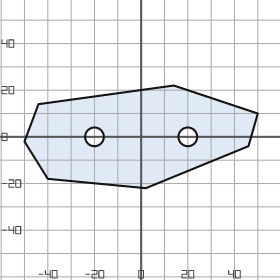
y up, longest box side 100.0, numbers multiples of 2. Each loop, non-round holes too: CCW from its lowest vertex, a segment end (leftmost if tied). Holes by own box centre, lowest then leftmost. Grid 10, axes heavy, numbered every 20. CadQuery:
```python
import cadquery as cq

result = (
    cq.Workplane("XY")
    .moveTo(2.0, -22.0)
    .lineTo(46.0, -4.0)
    .lineTo(50.0, 10.0)
    .lineTo(14.0, 22.0)
    .lineTo(-44.0, 14.0)
    .lineTo(-50.0, -2.0)
    .lineTo(-40.0, -18.0)
    .close()
    .moveTo(-20.0, 0.0)
    .circle(4.0)
    .moveTo(20.0, 0.0)
    .circle(4.0)
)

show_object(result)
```